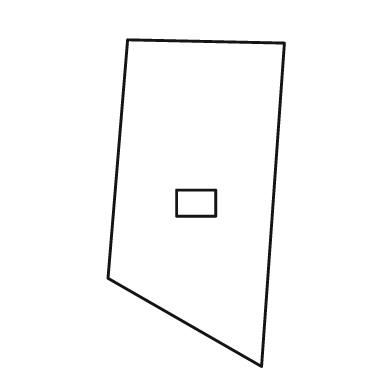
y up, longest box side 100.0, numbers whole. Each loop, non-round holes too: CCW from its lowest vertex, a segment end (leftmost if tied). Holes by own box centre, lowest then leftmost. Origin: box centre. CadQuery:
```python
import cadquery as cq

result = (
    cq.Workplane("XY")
    .moveTo(20.0, -50.0)
    .lineTo(27.0, 49.0)
    .lineTo(-21.0, 50.0)
    .lineTo(-27.0, -23.0)
    .close()
    .moveTo(-6.0, -4.0)
    .lineTo(6.0, -4.0)
    .lineTo(6.0, 4.0)
    .lineTo(-6.0, 4.0)
    .close()
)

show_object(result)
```